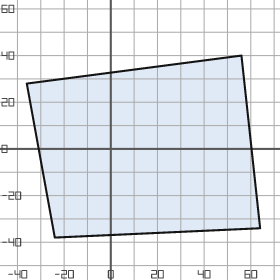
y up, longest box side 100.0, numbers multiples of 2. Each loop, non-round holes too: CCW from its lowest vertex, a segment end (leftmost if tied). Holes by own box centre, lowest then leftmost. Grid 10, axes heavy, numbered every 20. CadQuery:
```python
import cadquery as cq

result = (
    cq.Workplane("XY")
    .moveTo(-24.0, -38.0)
    .lineTo(64.0, -34.0)
    .lineTo(56.0, 40.0)
    .lineTo(-36.0, 28.0)
    .close()
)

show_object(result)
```